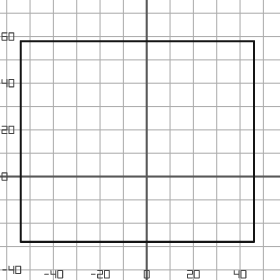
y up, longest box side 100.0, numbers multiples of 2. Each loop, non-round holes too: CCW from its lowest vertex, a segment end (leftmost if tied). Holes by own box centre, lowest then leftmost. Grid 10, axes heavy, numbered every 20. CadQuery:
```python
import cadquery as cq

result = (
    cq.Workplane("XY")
    .moveTo(-54.0, -28.0)
    .lineTo(46.0, -28.0)
    .lineTo(46.0, 58.0)
    .lineTo(-54.0, 58.0)
    .close()
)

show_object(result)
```